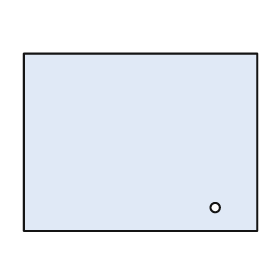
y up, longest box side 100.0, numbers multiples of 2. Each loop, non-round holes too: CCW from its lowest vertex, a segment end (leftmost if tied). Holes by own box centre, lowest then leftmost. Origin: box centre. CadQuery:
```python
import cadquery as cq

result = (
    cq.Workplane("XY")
    .moveTo(-50.0, -38.0)
    .lineTo(50.0, -38.0)
    .lineTo(50.0, 38.0)
    .lineTo(-50.0, 38.0)
    .close()
    .moveTo(32.0, -28.0)
    .circle(2.0)
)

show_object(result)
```